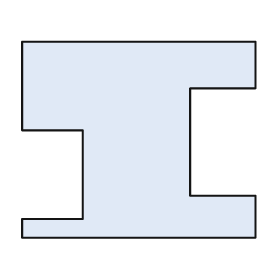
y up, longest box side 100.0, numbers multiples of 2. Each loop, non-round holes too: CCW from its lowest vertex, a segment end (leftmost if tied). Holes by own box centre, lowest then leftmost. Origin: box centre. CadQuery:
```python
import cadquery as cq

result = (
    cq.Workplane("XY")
    .moveTo(-50.0, -42.0)
    .lineTo(50.0, -42.0)
    .lineTo(50.0, -24.0)
    .lineTo(22.0, -24.0)
    .lineTo(22.0, 22.0)
    .lineTo(50.0, 22.0)
    .lineTo(50.0, 42.0)
    .lineTo(-50.0, 42.0)
    .lineTo(-50.0, 4.0)
    .lineTo(-24.0, 4.0)
    .lineTo(-24.0, -34.0)
    .lineTo(-50.0, -34.0)
    .close()
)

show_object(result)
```